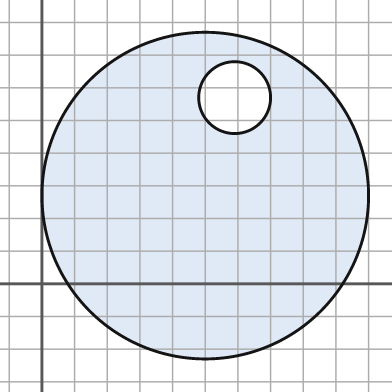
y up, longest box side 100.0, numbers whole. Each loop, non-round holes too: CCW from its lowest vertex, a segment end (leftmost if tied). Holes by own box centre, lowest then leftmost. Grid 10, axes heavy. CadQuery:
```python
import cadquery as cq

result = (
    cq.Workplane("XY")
    .moveTo(50.0, 27.0)
    .circle(50.0)
    .moveTo(59.0, 57.0)
    .circle(11.0)
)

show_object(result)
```